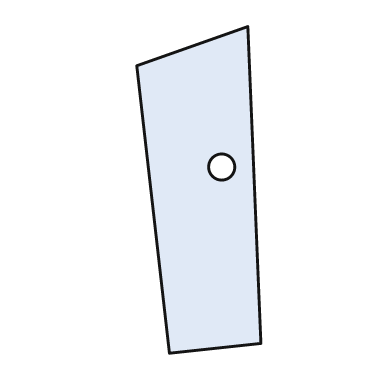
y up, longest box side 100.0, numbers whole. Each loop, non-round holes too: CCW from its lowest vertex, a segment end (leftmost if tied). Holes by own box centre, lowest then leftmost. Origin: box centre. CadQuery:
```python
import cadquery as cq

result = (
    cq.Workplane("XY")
    .moveTo(-9.0, -50.0)
    .lineTo(19.0, -47.0)
    .lineTo(15.0, 50.0)
    .lineTo(-19.0, 38.0)
    .close()
    .moveTo(7.0, 7.0)
    .circle(4.0)
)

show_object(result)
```